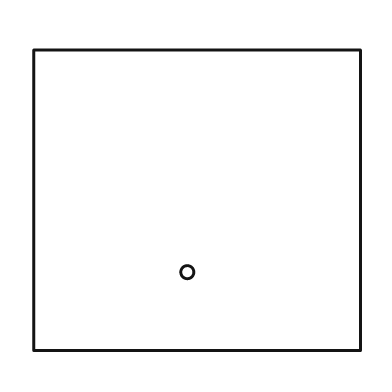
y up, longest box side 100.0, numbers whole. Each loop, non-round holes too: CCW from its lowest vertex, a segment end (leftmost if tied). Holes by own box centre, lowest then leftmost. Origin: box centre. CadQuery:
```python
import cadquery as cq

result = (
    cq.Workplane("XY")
    .moveTo(-50.0, -46.0)
    .lineTo(50.0, -46.0)
    .lineTo(50.0, 46.0)
    .lineTo(-50.0, 46.0)
    .close()
    .moveTo(-3.0, -22.0)
    .circle(2.0)
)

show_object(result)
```